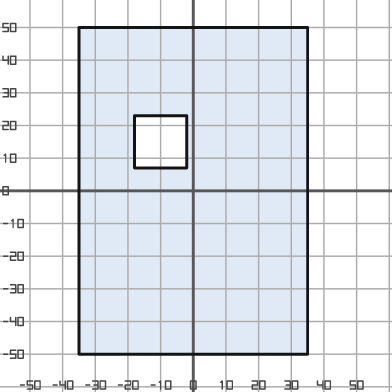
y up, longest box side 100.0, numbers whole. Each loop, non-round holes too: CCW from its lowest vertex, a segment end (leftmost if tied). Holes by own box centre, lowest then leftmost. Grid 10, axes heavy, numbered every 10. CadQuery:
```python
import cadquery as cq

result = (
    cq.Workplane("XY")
    .moveTo(-35.0, -50.0)
    .lineTo(35.0, -50.0)
    .lineTo(35.0, 50.0)
    .lineTo(-35.0, 50.0)
    .close()
    .moveTo(-18.0, 7.0)
    .lineTo(-2.0, 7.0)
    .lineTo(-2.0, 23.0)
    .lineTo(-18.0, 23.0)
    .close()
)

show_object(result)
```